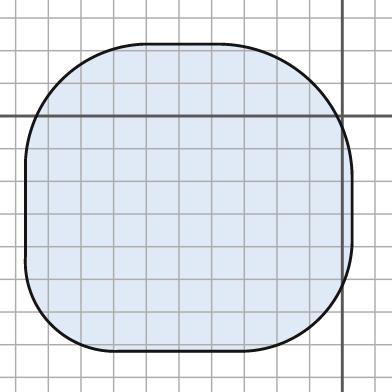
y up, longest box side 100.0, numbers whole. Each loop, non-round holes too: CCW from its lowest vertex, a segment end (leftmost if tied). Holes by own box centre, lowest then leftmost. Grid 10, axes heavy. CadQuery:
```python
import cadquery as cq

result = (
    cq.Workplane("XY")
    .moveTo(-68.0, -72.0)
    .lineTo(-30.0, -72.0)
    .threePointArc((-7.0, -62.0), (3.0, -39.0))
    .lineTo(3.0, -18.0)
    .threePointArc((-9.0, 10.0), (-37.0, 22.0))
    .lineTo(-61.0, 22.0)
    .threePointArc((-86.0, 11.0), (-97.0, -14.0))
    .lineTo(-97.0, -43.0)
    .threePointArc((-89.0, -64.0), (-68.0, -72.0))
    .close()
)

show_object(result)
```